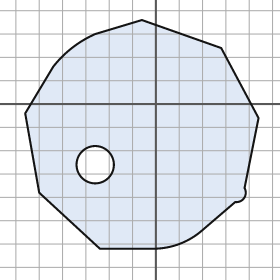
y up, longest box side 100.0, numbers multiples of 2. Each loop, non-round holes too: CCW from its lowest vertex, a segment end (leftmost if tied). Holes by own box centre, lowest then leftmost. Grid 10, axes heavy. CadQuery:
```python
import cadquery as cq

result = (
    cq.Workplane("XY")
    .moveTo(-24.0, -62.0)
    .lineTo(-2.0, -62.0)
    .threePointArc((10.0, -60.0), (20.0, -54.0))
    .lineTo(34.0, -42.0)
    .threePointArc((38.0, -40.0), (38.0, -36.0))
    .lineTo(44.0, -6.0)
    .lineTo(28.0, 24.0)
    .lineTo(-6.0, 36.0)
    .lineTo(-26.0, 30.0)
    .threePointArc((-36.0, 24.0), (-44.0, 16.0))
    .lineTo(-56.0, -4.0)
    .lineTo(-50.0, -38.0)
    .close()
    .moveTo(-26.0, -26.0)
    .circle(8.0)
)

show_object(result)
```